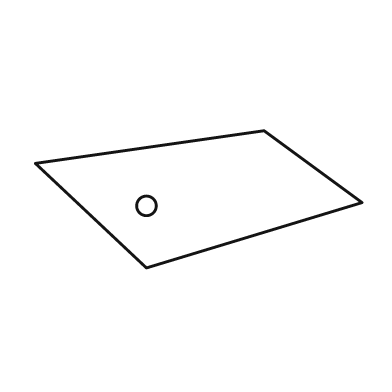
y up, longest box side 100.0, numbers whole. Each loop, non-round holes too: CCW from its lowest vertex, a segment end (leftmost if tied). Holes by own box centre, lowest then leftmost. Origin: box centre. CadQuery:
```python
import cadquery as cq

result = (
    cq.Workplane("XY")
    .moveTo(-16.0, -21.0)
    .lineTo(50.0, -1.0)
    .lineTo(20.0, 21.0)
    .lineTo(-50.0, 11.0)
    .close()
    .moveTo(-16.0, -2.0)
    .circle(3.0)
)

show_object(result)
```